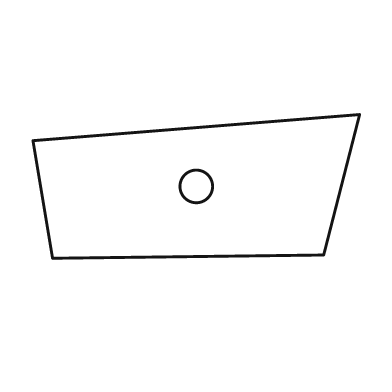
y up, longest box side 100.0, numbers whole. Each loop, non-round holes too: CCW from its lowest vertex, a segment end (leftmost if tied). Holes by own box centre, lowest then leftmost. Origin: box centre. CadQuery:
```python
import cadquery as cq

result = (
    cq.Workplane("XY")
    .moveTo(-44.0, -22.0)
    .lineTo(39.0, -21.0)
    .lineTo(50.0, 22.0)
    .lineTo(-50.0, 14.0)
    .close()
    .moveTo(0.0, 0.0)
    .circle(5.0)
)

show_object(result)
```